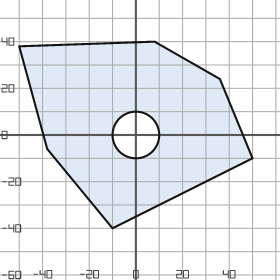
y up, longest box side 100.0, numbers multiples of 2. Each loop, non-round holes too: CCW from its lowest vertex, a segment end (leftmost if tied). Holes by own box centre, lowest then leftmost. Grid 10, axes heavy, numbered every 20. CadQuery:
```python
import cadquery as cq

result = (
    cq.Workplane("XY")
    .moveTo(-10.0, -40.0)
    .lineTo(50.0, -10.0)
    .lineTo(36.0, 24.0)
    .lineTo(8.0, 40.0)
    .lineTo(-50.0, 38.0)
    .lineTo(-38.0, -6.0)
    .close()
    .moveTo(0.0, 0.0)
    .circle(10.0)
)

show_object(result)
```